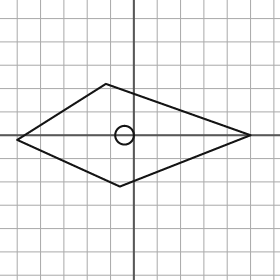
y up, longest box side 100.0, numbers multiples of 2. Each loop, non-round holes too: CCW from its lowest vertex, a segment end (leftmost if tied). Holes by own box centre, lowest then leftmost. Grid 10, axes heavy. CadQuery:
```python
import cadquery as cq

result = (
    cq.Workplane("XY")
    .moveTo(-6.0, -22.0)
    .lineTo(50.0, 0.0)
    .lineTo(-12.0, 22.0)
    .lineTo(-50.0, -2.0)
    .close()
    .moveTo(-4.0, 0.0)
    .circle(4.0)
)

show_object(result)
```